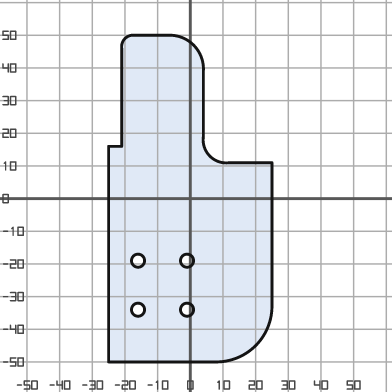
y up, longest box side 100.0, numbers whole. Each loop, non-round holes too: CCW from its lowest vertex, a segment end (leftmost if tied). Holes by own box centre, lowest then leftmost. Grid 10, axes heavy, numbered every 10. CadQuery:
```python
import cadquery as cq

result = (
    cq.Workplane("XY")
    .moveTo(-25.0, -50.0)
    .lineTo(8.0, -50.0)
    .threePointArc((20.0, -45.0), (25.0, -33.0))
    .lineTo(25.0, 11.0)
    .lineTo(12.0, 11.0)
    .threePointArc((6.0, 13.0), (4.0, 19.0))
    .lineTo(4.0, 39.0)
    .threePointArc((1.0, 47.0), (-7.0, 50.0))
    .lineTo(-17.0, 50.0)
    .threePointArc((-20.0, 49.0), (-21.0, 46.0))
    .lineTo(-21.0, 16.0)
    .lineTo(-25.0, 16.0)
    .close()
    .moveTo(-16.0, -34.0)
    .circle(2.0)
    .moveTo(-1.0, -34.0)
    .circle(2.0)
    .moveTo(-16.0, -19.0)
    .circle(2.0)
    .moveTo(-1.0, -19.0)
    .circle(2.0)
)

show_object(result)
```